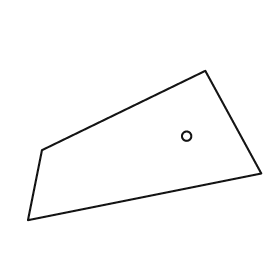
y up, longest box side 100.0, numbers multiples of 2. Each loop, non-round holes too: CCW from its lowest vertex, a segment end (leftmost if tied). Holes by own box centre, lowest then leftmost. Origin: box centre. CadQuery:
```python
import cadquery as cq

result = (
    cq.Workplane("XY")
    .moveTo(-50.0, -32.0)
    .lineTo(50.0, -12.0)
    .lineTo(26.0, 32.0)
    .lineTo(-44.0, -2.0)
    .close()
    .moveTo(18.0, 4.0)
    .circle(2.0)
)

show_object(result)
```